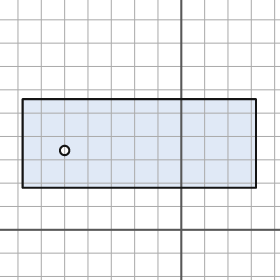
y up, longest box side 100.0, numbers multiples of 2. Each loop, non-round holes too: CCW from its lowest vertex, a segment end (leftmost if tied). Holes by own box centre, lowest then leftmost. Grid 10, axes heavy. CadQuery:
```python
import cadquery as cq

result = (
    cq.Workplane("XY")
    .moveTo(-68.0, 18.0)
    .lineTo(32.0, 18.0)
    .lineTo(32.0, 56.0)
    .lineTo(-68.0, 56.0)
    .close()
    .moveTo(-50.0, 34.0)
    .circle(2.0)
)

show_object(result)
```